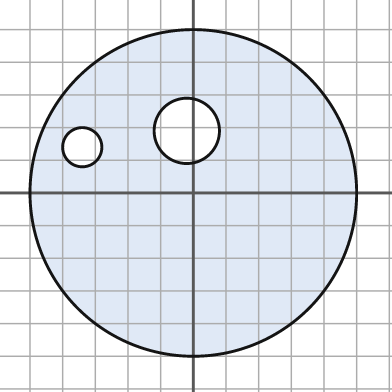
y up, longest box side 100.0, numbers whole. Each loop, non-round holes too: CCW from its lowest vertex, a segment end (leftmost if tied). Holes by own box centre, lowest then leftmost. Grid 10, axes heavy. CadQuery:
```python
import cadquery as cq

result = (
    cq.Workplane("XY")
    .moveTo(0.0, 0.0)
    .circle(50.0)
    .moveTo(-34.0, 14.0)
    .circle(6.0)
    .moveTo(-2.0, 19.0)
    .circle(10.0)
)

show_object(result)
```